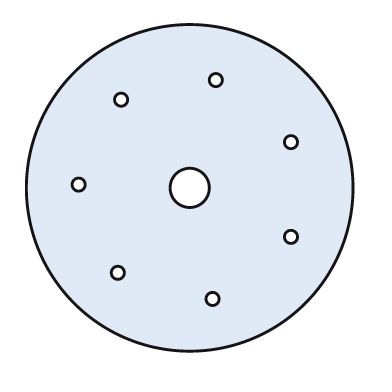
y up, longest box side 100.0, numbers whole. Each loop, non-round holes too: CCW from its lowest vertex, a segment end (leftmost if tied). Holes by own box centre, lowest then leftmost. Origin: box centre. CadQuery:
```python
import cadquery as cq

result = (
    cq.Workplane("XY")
    .moveTo(0.0, 0.0)
    .circle(50.0)
    .moveTo(7.0, -34.0)
    .circle(2.0)
    .moveTo(-22.0, -26.0)
    .circle(2.0)
    .moveTo(31.0, -15.0)
    .circle(2.0)
    .moveTo(0.0, 0.0)
    .circle(6.0)
    .moveTo(-34.0, 1.0)
    .circle(2.0)
    .moveTo(31.0, 14.0)
    .circle(2.0)
    .moveTo(-21.0, 27.0)
    .circle(2.0)
    .moveTo(8.0, 33.0)
    .circle(2.0)
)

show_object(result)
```